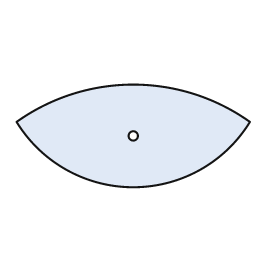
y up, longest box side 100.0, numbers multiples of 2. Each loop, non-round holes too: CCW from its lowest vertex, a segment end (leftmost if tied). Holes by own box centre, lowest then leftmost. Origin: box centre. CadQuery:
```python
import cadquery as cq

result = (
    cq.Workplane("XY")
    .moveTo(-50.0, 6.0)
    .threePointArc((0.0, -22.0), (50.0, 6.0))
    .threePointArc((0.0, 22.0), (-50.0, 6.0))
    .close()
    .moveTo(0.0, 0.0)
    .circle(2.0)
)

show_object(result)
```